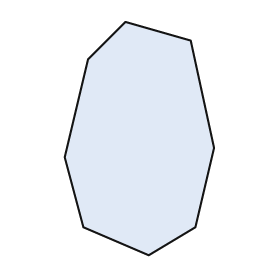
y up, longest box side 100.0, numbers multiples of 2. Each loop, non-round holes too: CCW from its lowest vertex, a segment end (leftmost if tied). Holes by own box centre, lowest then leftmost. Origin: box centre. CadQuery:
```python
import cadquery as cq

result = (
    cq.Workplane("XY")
    .moveTo(4.0, -50.0)
    .lineTo(24.0, -38.0)
    .lineTo(32.0, -4.0)
    .lineTo(22.0, 42.0)
    .lineTo(-6.0, 50.0)
    .lineTo(-22.0, 34.0)
    .lineTo(-32.0, -8.0)
    .lineTo(-24.0, -38.0)
    .close()
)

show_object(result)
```